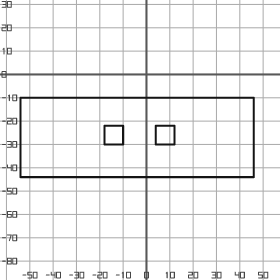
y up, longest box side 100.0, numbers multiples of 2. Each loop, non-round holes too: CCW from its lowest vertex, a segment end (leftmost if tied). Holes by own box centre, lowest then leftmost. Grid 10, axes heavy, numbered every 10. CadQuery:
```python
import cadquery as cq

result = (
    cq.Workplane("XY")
    .moveTo(-54.0, -44.0)
    .lineTo(46.0, -44.0)
    .lineTo(46.0, -10.0)
    .lineTo(-54.0, -10.0)
    .close()
    .moveTo(-18.0, -30.0)
    .lineTo(-10.0, -30.0)
    .lineTo(-10.0, -22.0)
    .lineTo(-18.0, -22.0)
    .close()
    .moveTo(4.0, -30.0)
    .lineTo(12.0, -30.0)
    .lineTo(12.0, -22.0)
    .lineTo(4.0, -22.0)
    .close()
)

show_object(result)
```